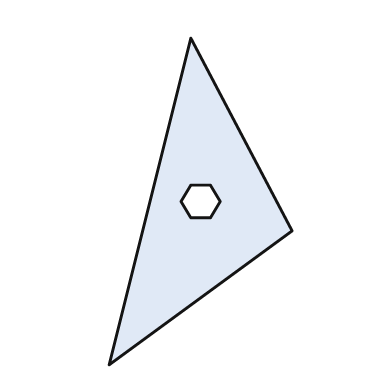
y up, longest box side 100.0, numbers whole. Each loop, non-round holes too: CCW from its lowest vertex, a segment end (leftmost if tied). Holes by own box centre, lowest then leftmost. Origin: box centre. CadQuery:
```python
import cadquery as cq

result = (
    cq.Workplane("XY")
    .moveTo(-28.0, -50.0)
    .lineTo(28.0, -9.0)
    .lineTo(-3.0, 50.0)
    .close()
    .moveTo(-3.0, -5.0)
    .lineTo(3.0, -5.0)
    .lineTo(6.0, 0.0)
    .lineTo(3.0, 5.0)
    .lineTo(-3.0, 5.0)
    .lineTo(-6.0, 0.0)
    .close()
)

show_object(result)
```